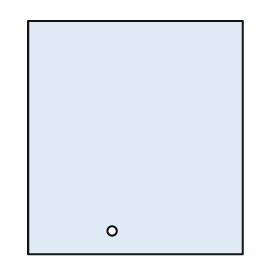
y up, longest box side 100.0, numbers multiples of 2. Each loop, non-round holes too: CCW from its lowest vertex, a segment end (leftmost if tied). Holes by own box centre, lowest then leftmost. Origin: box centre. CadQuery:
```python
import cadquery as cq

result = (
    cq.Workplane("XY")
    .moveTo(-46.0, -50.0)
    .lineTo(46.0, -50.0)
    .lineTo(46.0, 50.0)
    .lineTo(-46.0, 50.0)
    .close()
    .moveTo(-10.0, -40.0)
    .circle(2.0)
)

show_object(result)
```